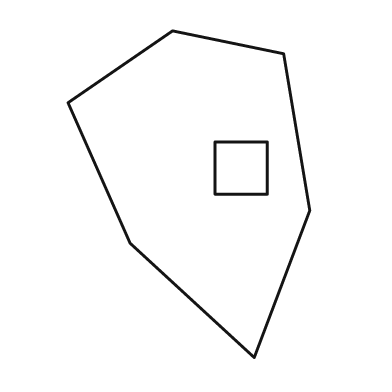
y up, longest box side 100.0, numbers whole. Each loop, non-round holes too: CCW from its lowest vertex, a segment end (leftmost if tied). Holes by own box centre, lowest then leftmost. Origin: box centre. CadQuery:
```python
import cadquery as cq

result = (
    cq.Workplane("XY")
    .moveTo(20.0, -50.0)
    .lineTo(37.0, -5.0)
    .lineTo(29.0, 43.0)
    .lineTo(-5.0, 50.0)
    .lineTo(-37.0, 28.0)
    .lineTo(-18.0, -15.0)
    .close()
    .moveTo(8.0, 0.0)
    .lineTo(24.0, 0.0)
    .lineTo(24.0, 16.0)
    .lineTo(8.0, 16.0)
    .close()
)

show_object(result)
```